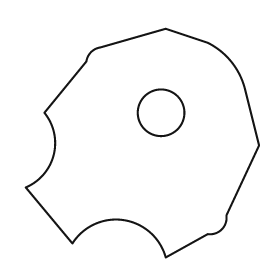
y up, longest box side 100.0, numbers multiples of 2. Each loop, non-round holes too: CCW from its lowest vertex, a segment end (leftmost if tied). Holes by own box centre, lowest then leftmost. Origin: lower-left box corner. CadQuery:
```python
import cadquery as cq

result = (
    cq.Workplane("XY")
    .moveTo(60.0, 0.0)
    .lineTo(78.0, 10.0)
    .threePointArc((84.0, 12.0), (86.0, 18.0))
    .lineTo(100.0, 48.0)
    .lineTo(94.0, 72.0)
    .threePointArc((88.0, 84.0), (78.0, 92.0))
    .lineTo(60.0, 98.0)
    .lineTo(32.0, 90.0)
    .threePointArc((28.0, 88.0), (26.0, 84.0))
    .lineTo(8.0, 62.0)
    .threePointArc((12.0, 44.0), (0.0, 30.0))
    .lineTo(20.0, 6.0)
    .threePointArc((42.0, 16.0), (60.0, 0.0))
    .close()
    .moveTo(58.0, 62.0)
    .circle(10.0)
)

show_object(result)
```